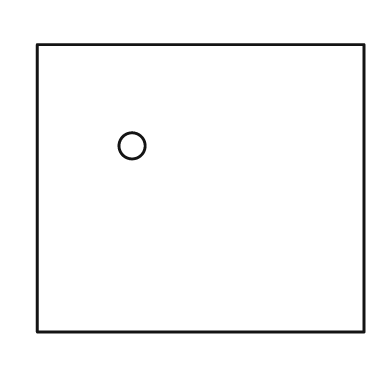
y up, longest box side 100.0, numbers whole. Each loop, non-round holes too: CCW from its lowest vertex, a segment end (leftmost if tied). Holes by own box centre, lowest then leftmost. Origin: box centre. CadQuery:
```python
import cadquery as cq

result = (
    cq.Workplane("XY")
    .moveTo(-50.0, -44.0)
    .lineTo(50.0, -44.0)
    .lineTo(50.0, 44.0)
    .lineTo(-50.0, 44.0)
    .close()
    .moveTo(-21.0, 13.0)
    .circle(4.0)
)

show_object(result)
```